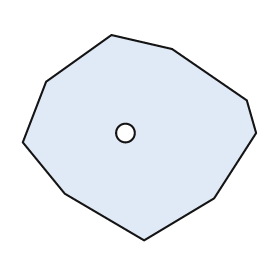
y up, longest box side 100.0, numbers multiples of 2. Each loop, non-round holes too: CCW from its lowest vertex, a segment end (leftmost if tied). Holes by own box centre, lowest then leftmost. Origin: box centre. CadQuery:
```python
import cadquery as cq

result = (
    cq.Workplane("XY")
    .moveTo(2.0, -44.0)
    .lineTo(32.0, -26.0)
    .lineTo(50.0, 2.0)
    .lineTo(46.0, 16.0)
    .lineTo(14.0, 38.0)
    .lineTo(-12.0, 44.0)
    .lineTo(-40.0, 24.0)
    .lineTo(-50.0, -2.0)
    .lineTo(-32.0, -24.0)
    .close()
    .moveTo(-6.0, 2.0)
    .circle(4.0)
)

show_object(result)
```